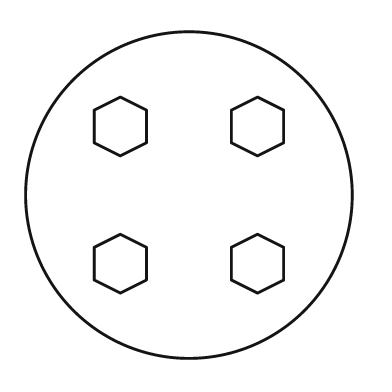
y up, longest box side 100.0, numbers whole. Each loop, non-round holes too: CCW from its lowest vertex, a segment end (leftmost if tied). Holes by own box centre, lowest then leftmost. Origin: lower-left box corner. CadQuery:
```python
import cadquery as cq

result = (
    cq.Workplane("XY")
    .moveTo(50.0, 50.0)
    .circle(50.0)
    .moveTo(29.0, 20.0)
    .lineTo(37.0, 24.0)
    .lineTo(37.0, 34.0)
    .lineTo(29.0, 38.0)
    .lineTo(21.0, 34.0)
    .lineTo(21.0, 24.0)
    .close()
    .moveTo(71.0, 20.0)
    .lineTo(79.0, 24.0)
    .lineTo(79.0, 34.0)
    .lineTo(71.0, 38.0)
    .lineTo(63.0, 34.0)
    .lineTo(63.0, 24.0)
    .close()
    .moveTo(29.0, 62.0)
    .lineTo(37.0, 66.0)
    .lineTo(37.0, 76.0)
    .lineTo(29.0, 80.0)
    .lineTo(21.0, 76.0)
    .lineTo(21.0, 66.0)
    .close()
    .moveTo(71.0, 62.0)
    .lineTo(79.0, 66.0)
    .lineTo(79.0, 76.0)
    .lineTo(71.0, 80.0)
    .lineTo(63.0, 76.0)
    .lineTo(63.0, 66.0)
    .close()
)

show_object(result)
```